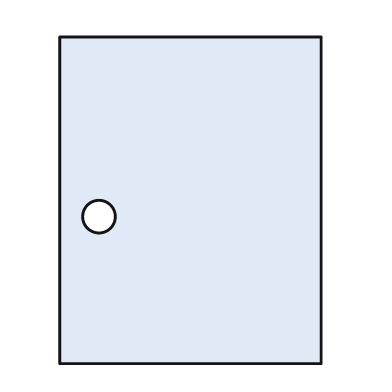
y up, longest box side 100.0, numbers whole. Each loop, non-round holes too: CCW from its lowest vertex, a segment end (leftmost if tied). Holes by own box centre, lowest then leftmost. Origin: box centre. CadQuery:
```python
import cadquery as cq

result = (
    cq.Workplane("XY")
    .moveTo(-40.0, -50.0)
    .lineTo(40.0, -50.0)
    .lineTo(40.0, 50.0)
    .lineTo(-40.0, 50.0)
    .close()
    .moveTo(-28.0, -5.0)
    .circle(5.0)
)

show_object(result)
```